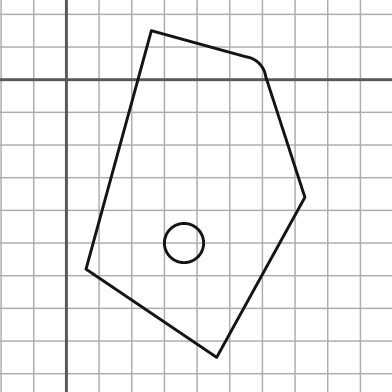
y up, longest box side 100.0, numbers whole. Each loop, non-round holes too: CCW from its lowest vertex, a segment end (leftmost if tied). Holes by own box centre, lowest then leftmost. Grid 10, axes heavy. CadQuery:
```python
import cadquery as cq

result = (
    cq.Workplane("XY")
    .moveTo(46.0, -85.0)
    .lineTo(73.0, -36.0)
    .lineTo(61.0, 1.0)
    .threePointArc((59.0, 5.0), (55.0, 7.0))
    .lineTo(26.0, 15.0)
    .lineTo(6.0, -58.0)
    .close()
    .moveTo(36.0, -50.0)
    .circle(6.0)
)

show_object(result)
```